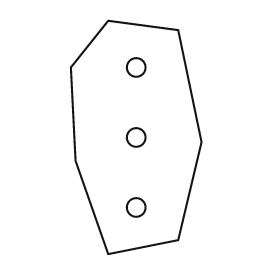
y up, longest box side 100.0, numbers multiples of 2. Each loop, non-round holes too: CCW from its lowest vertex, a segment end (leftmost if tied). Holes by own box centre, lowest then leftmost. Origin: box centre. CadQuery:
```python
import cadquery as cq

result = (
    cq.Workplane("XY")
    .moveTo(-12.0, -50.0)
    .lineTo(18.0, -44.0)
    .lineTo(28.0, -2.0)
    .lineTo(18.0, 46.0)
    .lineTo(-12.0, 50.0)
    .lineTo(-28.0, 30.0)
    .lineTo(-26.0, -10.0)
    .close()
    .moveTo(0.0, -30.0)
    .circle(4.0)
    .moveTo(0.0, 0.0)
    .circle(4.0)
    .moveTo(0.0, 30.0)
    .circle(4.0)
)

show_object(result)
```